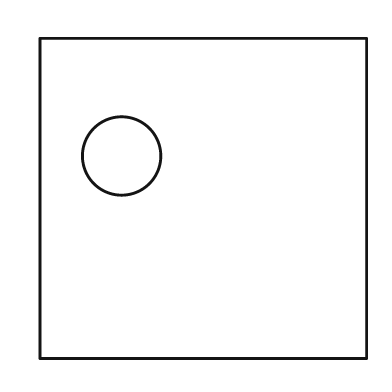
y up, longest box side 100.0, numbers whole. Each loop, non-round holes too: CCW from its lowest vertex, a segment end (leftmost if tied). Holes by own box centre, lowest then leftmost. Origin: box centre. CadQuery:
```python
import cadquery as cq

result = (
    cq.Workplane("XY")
    .moveTo(-50.0, -49.0)
    .lineTo(50.0, -49.0)
    .lineTo(50.0, 49.0)
    .lineTo(-50.0, 49.0)
    .close()
    .moveTo(-25.0, 13.0)
    .circle(12.0)
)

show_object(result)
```